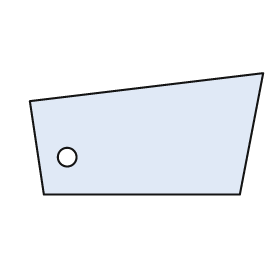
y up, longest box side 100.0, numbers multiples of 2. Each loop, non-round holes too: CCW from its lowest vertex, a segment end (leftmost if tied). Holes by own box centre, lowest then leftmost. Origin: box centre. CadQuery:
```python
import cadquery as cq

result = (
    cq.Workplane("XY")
    .moveTo(-44.0, -26.0)
    .lineTo(40.0, -26.0)
    .lineTo(50.0, 26.0)
    .lineTo(-50.0, 14.0)
    .close()
    .moveTo(-34.0, -10.0)
    .circle(4.0)
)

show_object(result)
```